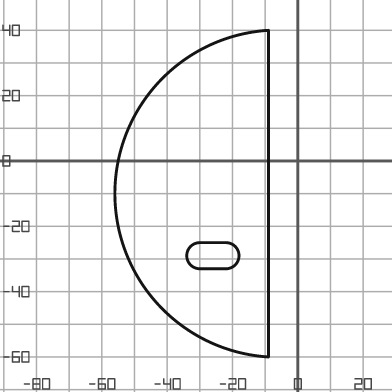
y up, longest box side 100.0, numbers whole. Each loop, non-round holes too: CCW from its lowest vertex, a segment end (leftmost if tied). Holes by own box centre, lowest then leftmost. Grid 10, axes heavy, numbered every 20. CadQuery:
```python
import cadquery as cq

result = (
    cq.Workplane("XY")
    .moveTo(-9.0, -60.0)
    .lineTo(-9.0, 40.0)
    .threePointArc((-56.0, -10.0), (-9.0, -60.0))
    .close()
    .moveTo(-30.0, -33.0)
    .lineTo(-22.0, -33.0)
    .threePointArc((-18.0, -29.0), (-22.0, -25.0))
    .lineTo(-30.0, -25.0)
    .threePointArc((-34.0, -29.0), (-30.0, -33.0))
    .close()
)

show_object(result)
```